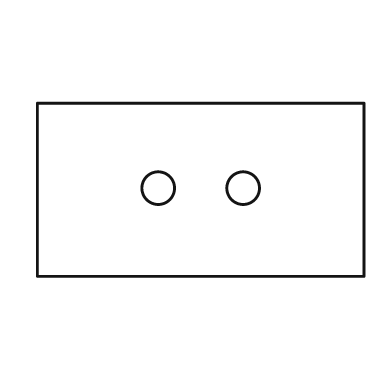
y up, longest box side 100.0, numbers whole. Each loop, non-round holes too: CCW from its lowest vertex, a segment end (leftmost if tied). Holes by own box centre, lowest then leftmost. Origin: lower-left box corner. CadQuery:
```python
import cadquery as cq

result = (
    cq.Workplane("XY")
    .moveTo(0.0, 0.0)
    .lineTo(100.0, 0.0)
    .lineTo(100.0, 53.0)
    .lineTo(0.0, 53.0)
    .close()
    .moveTo(37.0, 27.0)
    .circle(5.0)
    .moveTo(63.0, 27.0)
    .circle(5.0)
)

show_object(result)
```